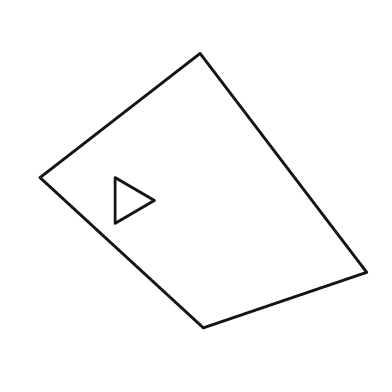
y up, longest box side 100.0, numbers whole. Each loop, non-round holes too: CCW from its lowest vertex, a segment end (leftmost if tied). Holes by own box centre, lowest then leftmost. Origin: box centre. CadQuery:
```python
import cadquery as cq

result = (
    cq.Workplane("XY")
    .moveTo(0.0, -42.0)
    .lineTo(50.0, -25.0)
    .lineTo(-1.0, 42.0)
    .lineTo(-50.0, 4.0)
    .close()
    .moveTo(-27.0, -10.0)
    .lineTo(-15.0, -3.0)
    .lineTo(-27.0, 4.0)
    .close()
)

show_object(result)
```